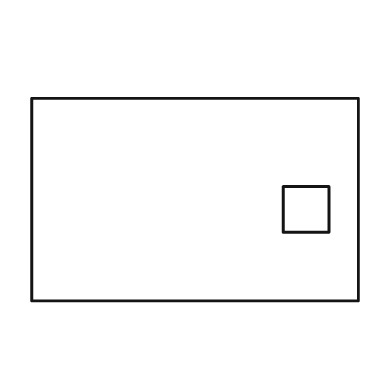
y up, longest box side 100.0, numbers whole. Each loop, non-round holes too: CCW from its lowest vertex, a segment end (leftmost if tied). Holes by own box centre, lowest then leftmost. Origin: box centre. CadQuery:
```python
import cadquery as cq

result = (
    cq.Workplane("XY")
    .moveTo(-50.0, -31.0)
    .lineTo(50.0, -31.0)
    .lineTo(50.0, 31.0)
    .lineTo(-50.0, 31.0)
    .close()
    .moveTo(27.0, -10.0)
    .lineTo(41.0, -10.0)
    .lineTo(41.0, 4.0)
    .lineTo(27.0, 4.0)
    .close()
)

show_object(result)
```